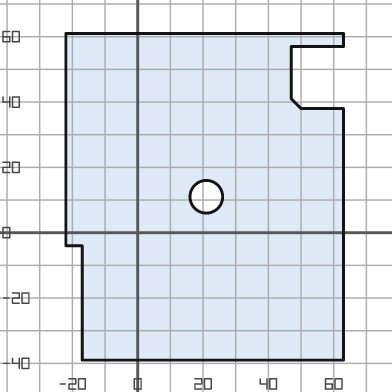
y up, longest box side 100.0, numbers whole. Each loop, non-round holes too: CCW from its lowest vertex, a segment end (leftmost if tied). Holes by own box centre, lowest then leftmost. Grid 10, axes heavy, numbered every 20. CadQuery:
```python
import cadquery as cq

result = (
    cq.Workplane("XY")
    .moveTo(-17.0, -39.0)
    .lineTo(63.0, -39.0)
    .lineTo(63.0, 38.0)
    .lineTo(50.0, 38.0)
    .lineTo(47.0, 41.0)
    .lineTo(47.0, 57.0)
    .lineTo(63.0, 57.0)
    .lineTo(63.0, 61.0)
    .lineTo(-22.0, 61.0)
    .lineTo(-22.0, -4.0)
    .lineTo(-17.0, -4.0)
    .close()
    .moveTo(21.0, 11.0)
    .circle(5.0)
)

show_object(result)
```